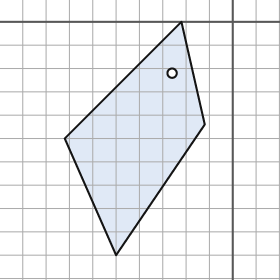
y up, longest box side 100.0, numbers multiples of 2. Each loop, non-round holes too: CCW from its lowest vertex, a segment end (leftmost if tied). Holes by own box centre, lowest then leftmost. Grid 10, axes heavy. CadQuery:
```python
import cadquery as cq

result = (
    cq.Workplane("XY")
    .moveTo(-50.0, -100.0)
    .lineTo(-12.0, -44.0)
    .lineTo(-22.0, 0.0)
    .lineTo(-72.0, -50.0)
    .close()
    .moveTo(-26.0, -22.0)
    .circle(2.0)
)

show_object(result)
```